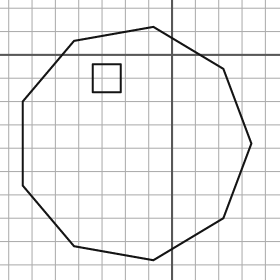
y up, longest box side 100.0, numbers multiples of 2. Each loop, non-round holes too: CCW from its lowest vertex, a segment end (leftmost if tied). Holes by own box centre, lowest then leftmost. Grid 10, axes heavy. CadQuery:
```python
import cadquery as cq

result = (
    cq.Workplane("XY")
    .moveTo(-8.0, -88.0)
    .lineTo(22.0, -70.0)
    .lineTo(34.0, -38.0)
    .lineTo(22.0, -6.0)
    .lineTo(-8.0, 12.0)
    .lineTo(-42.0, 6.0)
    .lineTo(-64.0, -20.0)
    .lineTo(-64.0, -56.0)
    .lineTo(-42.0, -82.0)
    .close()
    .moveTo(-34.0, -16.0)
    .lineTo(-22.0, -16.0)
    .lineTo(-22.0, -4.0)
    .lineTo(-34.0, -4.0)
    .close()
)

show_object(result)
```